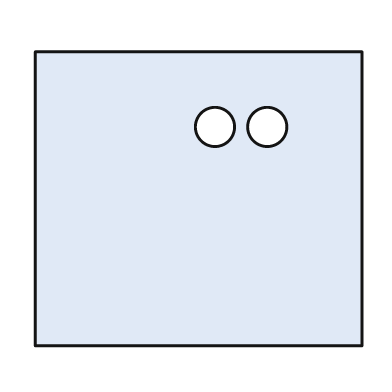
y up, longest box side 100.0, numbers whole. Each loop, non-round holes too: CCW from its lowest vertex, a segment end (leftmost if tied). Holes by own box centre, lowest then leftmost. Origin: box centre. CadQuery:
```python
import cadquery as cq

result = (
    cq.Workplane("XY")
    .moveTo(-50.0, -45.0)
    .lineTo(50.0, -45.0)
    .lineTo(50.0, 45.0)
    .lineTo(-50.0, 45.0)
    .close()
    .moveTo(5.0, 22.0)
    .circle(6.0)
    .moveTo(21.0, 22.0)
    .circle(6.0)
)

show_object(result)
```